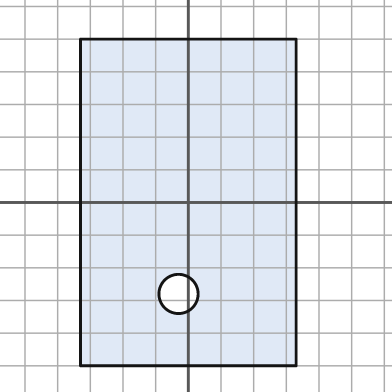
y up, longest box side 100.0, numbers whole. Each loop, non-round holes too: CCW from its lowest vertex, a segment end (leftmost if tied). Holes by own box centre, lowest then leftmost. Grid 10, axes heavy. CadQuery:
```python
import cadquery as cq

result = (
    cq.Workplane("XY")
    .moveTo(-33.0, -50.0)
    .lineTo(33.0, -50.0)
    .lineTo(33.0, 50.0)
    .lineTo(-33.0, 50.0)
    .close()
    .moveTo(-3.0, -28.0)
    .circle(6.0)
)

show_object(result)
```